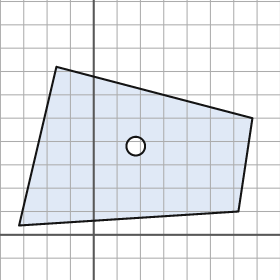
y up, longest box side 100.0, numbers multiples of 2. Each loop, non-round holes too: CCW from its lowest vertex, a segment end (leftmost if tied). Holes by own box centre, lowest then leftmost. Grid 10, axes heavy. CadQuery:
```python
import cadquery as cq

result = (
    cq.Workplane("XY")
    .moveTo(-32.0, 4.0)
    .lineTo(62.0, 10.0)
    .lineTo(68.0, 50.0)
    .lineTo(-16.0, 72.0)
    .close()
    .moveTo(18.0, 38.0)
    .circle(4.0)
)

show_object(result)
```